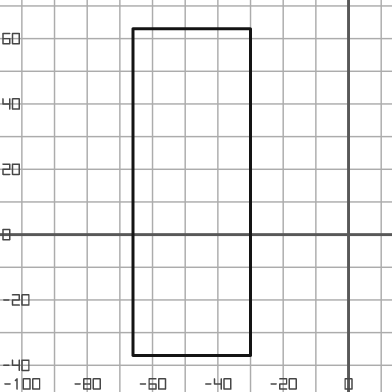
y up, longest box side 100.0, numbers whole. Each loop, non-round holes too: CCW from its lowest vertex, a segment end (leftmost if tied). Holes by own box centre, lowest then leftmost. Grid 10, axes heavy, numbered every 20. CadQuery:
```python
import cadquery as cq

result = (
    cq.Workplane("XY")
    .moveTo(-66.0, -37.0)
    .lineTo(-30.0, -37.0)
    .lineTo(-30.0, 63.0)
    .lineTo(-66.0, 63.0)
    .close()
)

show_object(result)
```